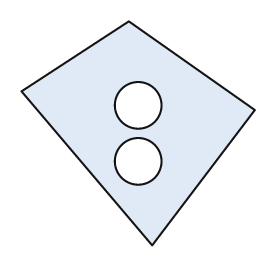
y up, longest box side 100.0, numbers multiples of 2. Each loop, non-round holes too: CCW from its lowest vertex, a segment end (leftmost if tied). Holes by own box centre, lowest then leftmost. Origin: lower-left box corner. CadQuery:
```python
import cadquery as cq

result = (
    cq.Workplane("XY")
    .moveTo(56.0, 0.0)
    .lineTo(100.0, 58.0)
    .lineTo(46.0, 96.0)
    .lineTo(0.0, 66.0)
    .close()
    .moveTo(50.0, 36.0)
    .circle(10.0)
    .moveTo(50.0, 60.0)
    .circle(10.0)
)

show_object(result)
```